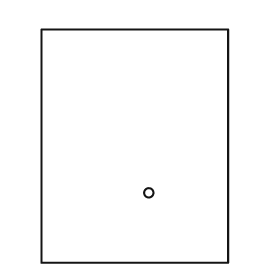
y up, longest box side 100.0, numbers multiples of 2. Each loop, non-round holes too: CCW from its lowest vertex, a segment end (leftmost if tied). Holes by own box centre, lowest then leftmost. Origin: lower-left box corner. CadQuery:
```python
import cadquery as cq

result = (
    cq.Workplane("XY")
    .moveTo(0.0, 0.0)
    .lineTo(80.0, 0.0)
    .lineTo(80.0, 100.0)
    .lineTo(0.0, 100.0)
    .close()
    .moveTo(46.0, 30.0)
    .circle(2.0)
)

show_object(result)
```